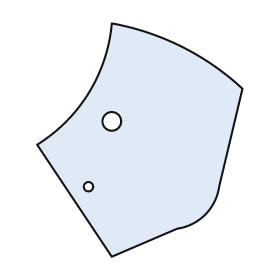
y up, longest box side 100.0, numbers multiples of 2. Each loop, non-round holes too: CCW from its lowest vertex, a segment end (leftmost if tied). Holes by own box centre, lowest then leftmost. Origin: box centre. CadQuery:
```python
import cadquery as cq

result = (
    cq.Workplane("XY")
    .moveTo(-12.0, -50.0)
    .lineTo(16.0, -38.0)
    .threePointArc((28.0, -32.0), (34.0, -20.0))
    .lineTo(44.0, 22.0)
    .threePointArc((18.0, 40.0), (-12.0, 50.0))
    .threePointArc((-22.0, 20.0), (-44.0, -2.0))
    .close()
    .moveTo(-22.0, -20.0)
    .circle(2.0)
    .moveTo(-12.0, 8.0)
    .circle(4.0)
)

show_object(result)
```